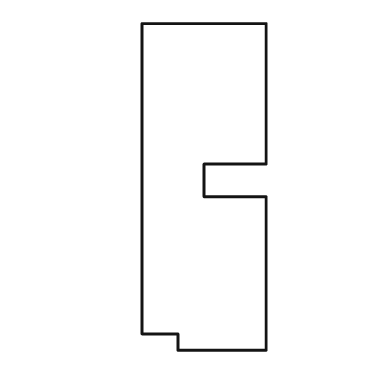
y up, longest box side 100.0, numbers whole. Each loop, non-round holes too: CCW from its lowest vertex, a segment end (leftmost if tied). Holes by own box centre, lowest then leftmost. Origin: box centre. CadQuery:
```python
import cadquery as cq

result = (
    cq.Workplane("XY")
    .moveTo(-8.0, -50.0)
    .lineTo(19.0, -50.0)
    .lineTo(19.0, -3.0)
    .lineTo(0.0, -3.0)
    .lineTo(0.0, 7.0)
    .lineTo(19.0, 7.0)
    .lineTo(19.0, 50.0)
    .lineTo(-19.0, 50.0)
    .lineTo(-19.0, -45.0)
    .lineTo(-8.0, -45.0)
    .close()
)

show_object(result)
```